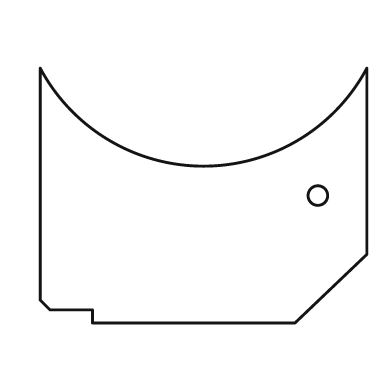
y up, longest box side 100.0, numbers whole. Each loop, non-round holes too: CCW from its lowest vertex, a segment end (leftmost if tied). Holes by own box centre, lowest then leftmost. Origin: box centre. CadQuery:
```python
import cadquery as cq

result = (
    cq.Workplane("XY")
    .moveTo(-34.0, -39.0)
    .lineTo(28.0, -39.0)
    .lineTo(50.0, -18.0)
    .lineTo(50.0, 39.0)
    .threePointArc((0.0, 9.0), (-50.0, 39.0))
    .lineTo(-50.0, -32.0)
    .lineTo(-47.0, -35.0)
    .lineTo(-34.0, -35.0)
    .close()
    .moveTo(35.0, 0.0)
    .circle(3.0)
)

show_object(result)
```